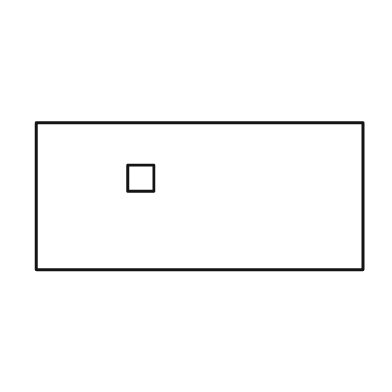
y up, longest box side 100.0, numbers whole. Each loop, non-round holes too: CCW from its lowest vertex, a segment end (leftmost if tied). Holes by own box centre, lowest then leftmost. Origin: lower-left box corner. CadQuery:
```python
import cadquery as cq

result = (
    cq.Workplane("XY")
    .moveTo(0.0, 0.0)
    .lineTo(100.0, 0.0)
    .lineTo(100.0, 45.0)
    .lineTo(0.0, 45.0)
    .close()
    .moveTo(28.0, 24.0)
    .lineTo(36.0, 24.0)
    .lineTo(36.0, 32.0)
    .lineTo(28.0, 32.0)
    .close()
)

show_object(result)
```